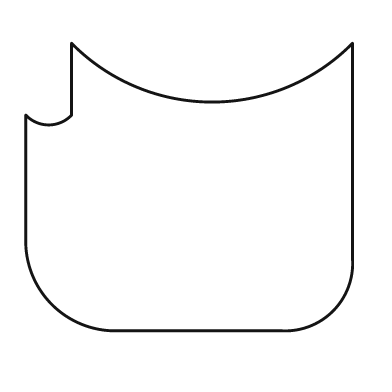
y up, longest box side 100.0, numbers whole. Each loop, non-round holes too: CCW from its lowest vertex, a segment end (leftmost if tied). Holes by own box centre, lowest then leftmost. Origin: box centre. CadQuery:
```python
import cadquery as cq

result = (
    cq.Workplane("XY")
    .moveTo(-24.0, -44.0)
    .lineTo(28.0, -44.0)
    .threePointArc((44.0, -38.0), (50.0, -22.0))
    .lineTo(50.0, 44.0)
    .threePointArc((7.0, 26.0), (-36.0, 44.0))
    .lineTo(-36.0, 22.0)
    .threePointArc((-43.0, 19.0), (-50.0, 22.0))
    .lineTo(-50.0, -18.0)
    .threePointArc((-42.0, -36.0), (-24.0, -44.0))
    .close()
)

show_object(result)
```